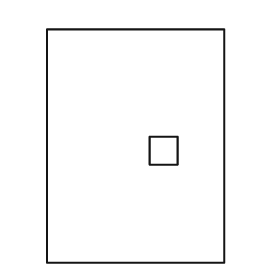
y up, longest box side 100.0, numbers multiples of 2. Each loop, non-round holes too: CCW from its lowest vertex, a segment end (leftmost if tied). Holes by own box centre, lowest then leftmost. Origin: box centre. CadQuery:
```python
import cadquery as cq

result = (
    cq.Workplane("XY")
    .moveTo(-38.0, -50.0)
    .lineTo(38.0, -50.0)
    .lineTo(38.0, 50.0)
    .lineTo(-38.0, 50.0)
    .close()
    .moveTo(6.0, -8.0)
    .lineTo(18.0, -8.0)
    .lineTo(18.0, 4.0)
    .lineTo(6.0, 4.0)
    .close()
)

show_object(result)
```